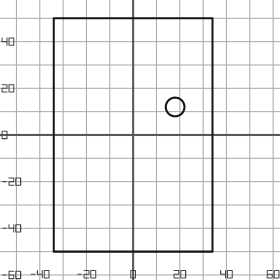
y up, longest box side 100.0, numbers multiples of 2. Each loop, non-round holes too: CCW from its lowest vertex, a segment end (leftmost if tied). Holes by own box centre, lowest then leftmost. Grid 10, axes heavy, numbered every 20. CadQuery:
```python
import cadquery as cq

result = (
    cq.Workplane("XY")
    .moveTo(-34.0, -50.0)
    .lineTo(34.0, -50.0)
    .lineTo(34.0, 50.0)
    .lineTo(-34.0, 50.0)
    .close()
    .moveTo(18.0, 12.0)
    .circle(4.0)
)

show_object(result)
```